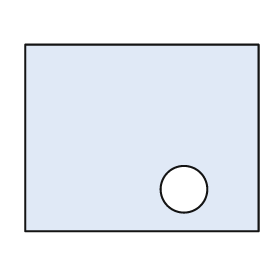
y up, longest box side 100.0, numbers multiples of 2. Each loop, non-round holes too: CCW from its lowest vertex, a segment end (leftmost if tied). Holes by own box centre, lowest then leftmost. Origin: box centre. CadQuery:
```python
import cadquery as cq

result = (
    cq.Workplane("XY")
    .moveTo(-50.0, -40.0)
    .lineTo(50.0, -40.0)
    .lineTo(50.0, 40.0)
    .lineTo(-50.0, 40.0)
    .close()
    .moveTo(18.0, -22.0)
    .circle(10.0)
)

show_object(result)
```